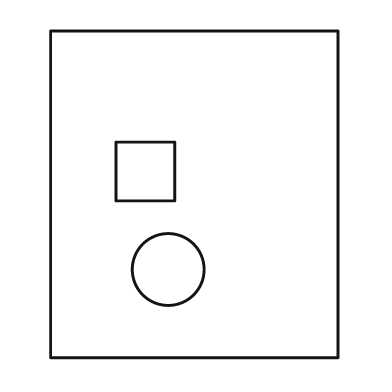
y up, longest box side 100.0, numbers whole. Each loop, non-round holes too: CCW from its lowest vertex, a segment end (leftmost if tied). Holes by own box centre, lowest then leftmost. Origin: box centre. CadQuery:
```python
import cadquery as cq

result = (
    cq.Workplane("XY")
    .moveTo(-44.0, -50.0)
    .lineTo(44.0, -50.0)
    .lineTo(44.0, 50.0)
    .lineTo(-44.0, 50.0)
    .close()
    .moveTo(-8.0, -23.0)
    .circle(11.0)
    .moveTo(-24.0, -2.0)
    .lineTo(-6.0, -2.0)
    .lineTo(-6.0, 16.0)
    .lineTo(-24.0, 16.0)
    .close()
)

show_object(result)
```